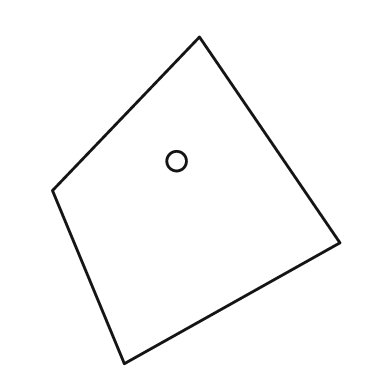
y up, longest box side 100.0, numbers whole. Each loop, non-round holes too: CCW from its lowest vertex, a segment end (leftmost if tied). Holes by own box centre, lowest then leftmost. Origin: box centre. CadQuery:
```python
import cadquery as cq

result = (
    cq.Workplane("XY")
    .moveTo(-22.0, -50.0)
    .lineTo(44.0, -13.0)
    .lineTo(1.0, 50.0)
    .lineTo(-44.0, 3.0)
    .close()
    .moveTo(-6.0, 12.0)
    .circle(3.0)
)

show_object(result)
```